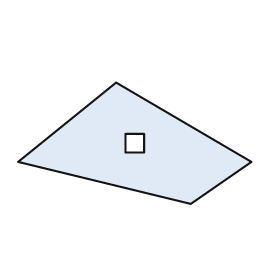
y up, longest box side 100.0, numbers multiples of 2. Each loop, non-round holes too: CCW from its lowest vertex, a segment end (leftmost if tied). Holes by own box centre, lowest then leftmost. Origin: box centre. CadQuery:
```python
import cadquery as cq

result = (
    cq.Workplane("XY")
    .moveTo(24.0, -26.0)
    .lineTo(50.0, -8.0)
    .lineTo(-8.0, 26.0)
    .lineTo(-50.0, -8.0)
    .close()
    .moveTo(-4.0, -4.0)
    .lineTo(4.0, -4.0)
    .lineTo(4.0, 4.0)
    .lineTo(-4.0, 4.0)
    .close()
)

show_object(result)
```